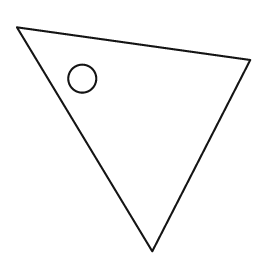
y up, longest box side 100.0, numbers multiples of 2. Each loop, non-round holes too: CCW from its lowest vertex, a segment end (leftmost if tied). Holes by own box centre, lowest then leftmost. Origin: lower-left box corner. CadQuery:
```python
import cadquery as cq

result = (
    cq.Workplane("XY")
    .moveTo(58.0, 0.0)
    .lineTo(100.0, 82.0)
    .lineTo(0.0, 96.0)
    .close()
    .moveTo(28.0, 74.0)
    .circle(6.0)
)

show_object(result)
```